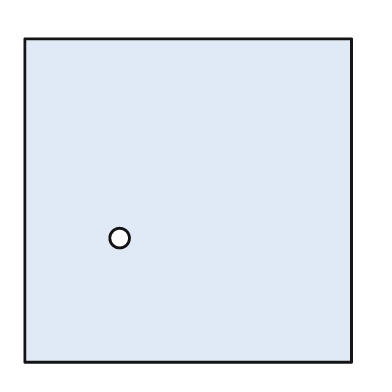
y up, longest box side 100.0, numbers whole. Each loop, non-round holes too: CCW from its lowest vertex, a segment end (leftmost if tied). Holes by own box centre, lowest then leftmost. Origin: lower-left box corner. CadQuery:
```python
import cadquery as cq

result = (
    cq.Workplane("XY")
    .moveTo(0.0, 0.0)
    .lineTo(100.0, 0.0)
    .lineTo(100.0, 99.0)
    .lineTo(0.0, 99.0)
    .close()
    .moveTo(29.0, 38.0)
    .circle(3.0)
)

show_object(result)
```